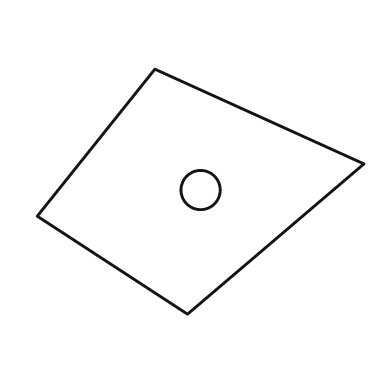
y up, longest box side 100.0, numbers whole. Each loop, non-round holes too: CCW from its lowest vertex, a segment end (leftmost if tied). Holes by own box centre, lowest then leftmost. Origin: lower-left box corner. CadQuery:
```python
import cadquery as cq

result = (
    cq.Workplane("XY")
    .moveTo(46.0, 0.0)
    .lineTo(100.0, 46.0)
    .lineTo(36.0, 75.0)
    .lineTo(0.0, 30.0)
    .close()
    .moveTo(50.0, 38.0)
    .circle(6.0)
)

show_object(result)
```